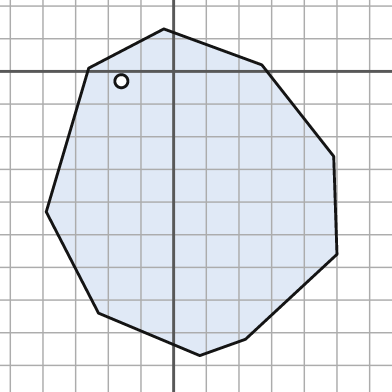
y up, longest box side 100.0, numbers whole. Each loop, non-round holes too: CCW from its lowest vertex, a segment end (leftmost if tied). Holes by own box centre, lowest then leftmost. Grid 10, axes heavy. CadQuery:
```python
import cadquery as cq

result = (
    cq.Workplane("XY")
    .moveTo(8.0, -87.0)
    .lineTo(22.0, -82.0)
    .lineTo(50.0, -56.0)
    .lineTo(49.0, -26.0)
    .lineTo(27.0, 2.0)
    .lineTo(-3.0, 13.0)
    .lineTo(-26.0, 1.0)
    .lineTo(-39.0, -43.0)
    .lineTo(-23.0, -74.0)
    .close()
    .moveTo(-16.0, -3.0)
    .circle(2.0)
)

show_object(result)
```